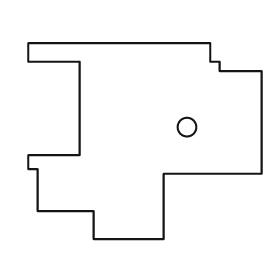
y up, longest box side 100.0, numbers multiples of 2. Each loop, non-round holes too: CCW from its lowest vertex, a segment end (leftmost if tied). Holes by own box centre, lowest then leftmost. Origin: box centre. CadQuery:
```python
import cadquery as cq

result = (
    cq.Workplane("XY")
    .moveTo(-22.0, -42.0)
    .lineTo(8.0, -42.0)
    .lineTo(8.0, -14.0)
    .lineTo(50.0, -14.0)
    .lineTo(50.0, 30.0)
    .lineTo(32.0, 30.0)
    .lineTo(32.0, 34.0)
    .lineTo(28.0, 34.0)
    .lineTo(28.0, 42.0)
    .lineTo(-50.0, 42.0)
    .lineTo(-50.0, 34.0)
    .lineTo(-28.0, 34.0)
    .lineTo(-28.0, -6.0)
    .lineTo(-50.0, -6.0)
    .lineTo(-50.0, -12.0)
    .lineTo(-46.0, -12.0)
    .lineTo(-46.0, -30.0)
    .lineTo(-22.0, -30.0)
    .close()
    .moveTo(18.0, 6.0)
    .circle(4.0)
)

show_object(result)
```